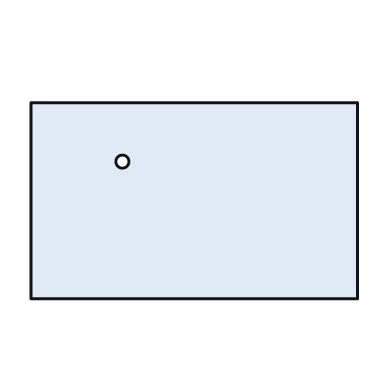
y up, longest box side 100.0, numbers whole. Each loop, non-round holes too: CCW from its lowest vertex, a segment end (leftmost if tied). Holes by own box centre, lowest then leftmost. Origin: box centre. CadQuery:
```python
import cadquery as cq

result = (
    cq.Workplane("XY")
    .moveTo(-50.0, -30.0)
    .lineTo(50.0, -30.0)
    .lineTo(50.0, 30.0)
    .lineTo(-50.0, 30.0)
    .close()
    .moveTo(-22.0, 12.0)
    .circle(2.0)
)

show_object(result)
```